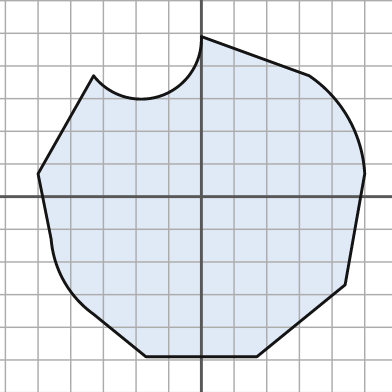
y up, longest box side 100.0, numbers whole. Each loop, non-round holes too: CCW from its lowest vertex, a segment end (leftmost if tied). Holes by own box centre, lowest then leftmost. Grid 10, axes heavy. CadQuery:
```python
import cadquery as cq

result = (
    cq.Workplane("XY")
    .moveTo(-17.0, -49.0)
    .lineTo(17.0, -49.0)
    .lineTo(44.0, -27.0)
    .lineTo(50.0, 7.0)
    .threePointArc((45.0, 24.0), (33.0, 37.0))
    .lineTo(0.0, 49.0)
    .threePointArc((-12.0, 31.0), (-33.0, 37.0))
    .lineTo(-50.0, 7.0)
    .lineTo(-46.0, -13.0)
    .threePointArc((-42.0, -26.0), (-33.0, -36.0))
    .close()
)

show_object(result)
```